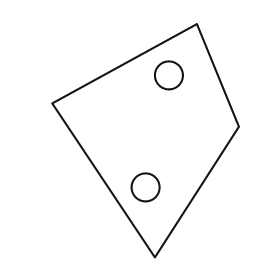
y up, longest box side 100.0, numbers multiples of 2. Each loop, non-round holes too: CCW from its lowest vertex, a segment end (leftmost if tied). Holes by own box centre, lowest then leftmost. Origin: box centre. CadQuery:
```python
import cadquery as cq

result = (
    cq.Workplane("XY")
    .moveTo(4.0, -50.0)
    .lineTo(40.0, 6.0)
    .lineTo(22.0, 50.0)
    .lineTo(-40.0, 16.0)
    .close()
    .moveTo(0.0, -20.0)
    .circle(6.0)
    .moveTo(10.0, 28.0)
    .circle(6.0)
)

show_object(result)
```